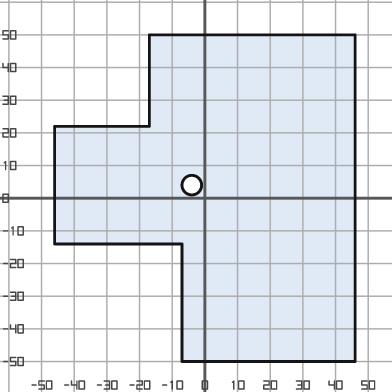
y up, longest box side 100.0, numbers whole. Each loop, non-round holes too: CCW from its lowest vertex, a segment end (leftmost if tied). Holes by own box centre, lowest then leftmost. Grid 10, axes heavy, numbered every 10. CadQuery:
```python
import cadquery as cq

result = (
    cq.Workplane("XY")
    .moveTo(-7.0, -50.0)
    .lineTo(46.0, -50.0)
    .lineTo(46.0, 50.0)
    .lineTo(-17.0, 50.0)
    .lineTo(-17.0, 22.0)
    .lineTo(-46.0, 22.0)
    .lineTo(-46.0, -14.0)
    .lineTo(-7.0, -14.0)
    .close()
    .moveTo(-4.0, 4.0)
    .circle(3.0)
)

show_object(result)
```